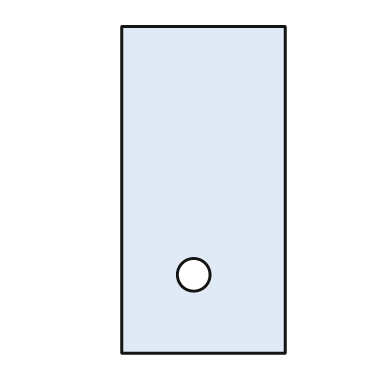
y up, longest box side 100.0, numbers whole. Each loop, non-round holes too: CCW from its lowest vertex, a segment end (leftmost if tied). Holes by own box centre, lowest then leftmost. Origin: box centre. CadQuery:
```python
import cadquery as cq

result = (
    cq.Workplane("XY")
    .moveTo(-25.0, -50.0)
    .lineTo(25.0, -50.0)
    .lineTo(25.0, 50.0)
    .lineTo(-25.0, 50.0)
    .close()
    .moveTo(-3.0, -26.0)
    .circle(5.0)
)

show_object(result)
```